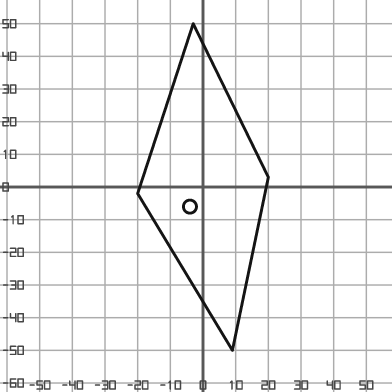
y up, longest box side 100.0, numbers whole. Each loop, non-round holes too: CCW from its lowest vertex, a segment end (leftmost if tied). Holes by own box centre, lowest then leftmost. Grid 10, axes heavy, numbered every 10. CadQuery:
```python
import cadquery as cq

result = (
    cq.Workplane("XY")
    .moveTo(9.0, -50.0)
    .lineTo(20.0, 3.0)
    .lineTo(-3.0, 50.0)
    .lineTo(-20.0, -2.0)
    .close()
    .moveTo(-4.0, -6.0)
    .circle(2.0)
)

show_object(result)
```